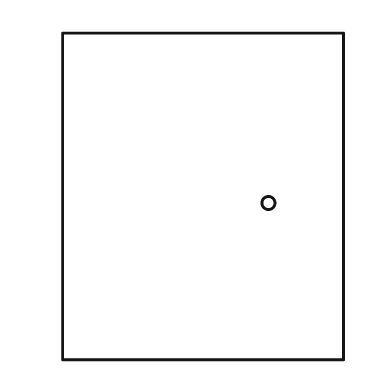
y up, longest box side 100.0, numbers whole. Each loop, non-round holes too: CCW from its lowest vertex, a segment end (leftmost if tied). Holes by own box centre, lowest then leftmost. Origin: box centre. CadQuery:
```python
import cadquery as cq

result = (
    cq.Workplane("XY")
    .moveTo(-43.0, -50.0)
    .lineTo(43.0, -50.0)
    .lineTo(43.0, 50.0)
    .lineTo(-43.0, 50.0)
    .close()
    .moveTo(20.0, -2.0)
    .circle(2.0)
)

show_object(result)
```